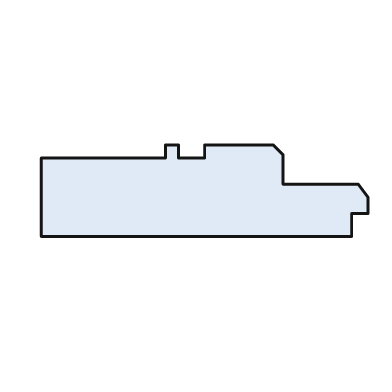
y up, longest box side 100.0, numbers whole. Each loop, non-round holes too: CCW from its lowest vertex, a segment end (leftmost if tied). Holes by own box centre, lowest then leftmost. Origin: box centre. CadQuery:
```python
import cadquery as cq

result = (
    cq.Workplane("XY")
    .moveTo(-50.0, -14.0)
    .lineTo(45.0, -14.0)
    .lineTo(45.0, -7.0)
    .lineTo(50.0, -7.0)
    .lineTo(50.0, -2.0)
    .lineTo(47.0, 2.0)
    .lineTo(24.0, 2.0)
    .lineTo(24.0, 11.0)
    .lineTo(21.0, 14.0)
    .lineTo(0.0, 14.0)
    .lineTo(0.0, 10.0)
    .lineTo(-8.0, 10.0)
    .lineTo(-8.0, 14.0)
    .lineTo(-12.0, 14.0)
    .lineTo(-12.0, 10.0)
    .lineTo(-50.0, 10.0)
    .close()
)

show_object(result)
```